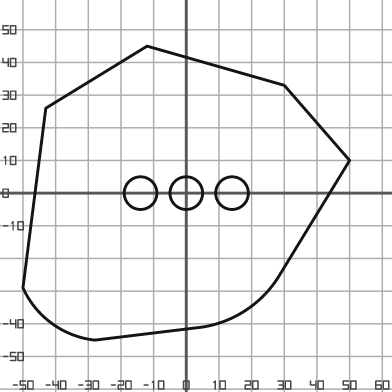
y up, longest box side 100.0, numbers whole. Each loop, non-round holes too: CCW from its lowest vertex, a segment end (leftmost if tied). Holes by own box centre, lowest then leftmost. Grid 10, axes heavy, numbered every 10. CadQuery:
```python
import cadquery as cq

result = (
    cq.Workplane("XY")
    .moveTo(-28.0, -45.0)
    .lineTo(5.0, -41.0)
    .threePointArc((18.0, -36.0), (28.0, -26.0))
    .lineTo(50.0, 10.0)
    .lineTo(30.0, 33.0)
    .lineTo(-12.0, 45.0)
    .lineTo(-43.0, 26.0)
    .lineTo(-50.0, -29.0)
    .threePointArc((-41.0, -40.0), (-28.0, -45.0))
    .close()
    .moveTo(-14.0, 0.0)
    .circle(5.0)
    .moveTo(0.0, 0.0)
    .circle(5.0)
    .moveTo(14.0, 0.0)
    .circle(5.0)
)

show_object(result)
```